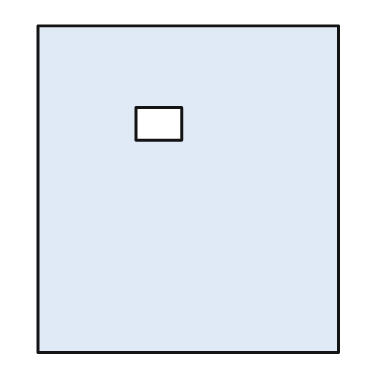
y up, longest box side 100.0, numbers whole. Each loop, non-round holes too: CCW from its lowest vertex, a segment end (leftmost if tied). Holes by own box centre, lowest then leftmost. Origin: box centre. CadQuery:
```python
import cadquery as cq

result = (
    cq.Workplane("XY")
    .moveTo(-46.0, -50.0)
    .lineTo(46.0, -50.0)
    .lineTo(46.0, 50.0)
    .lineTo(-46.0, 50.0)
    .close()
    .moveTo(-16.0, 15.0)
    .lineTo(-2.0, 15.0)
    .lineTo(-2.0, 25.0)
    .lineTo(-16.0, 25.0)
    .close()
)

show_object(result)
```